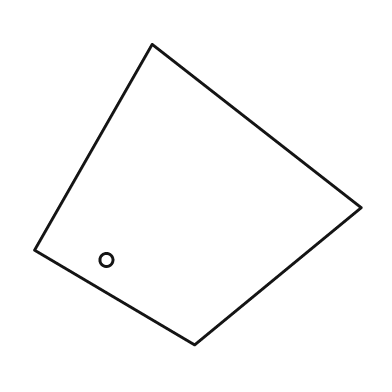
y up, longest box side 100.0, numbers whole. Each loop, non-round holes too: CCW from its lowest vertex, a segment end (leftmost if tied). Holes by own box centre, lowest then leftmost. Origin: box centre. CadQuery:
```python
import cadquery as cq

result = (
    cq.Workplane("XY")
    .moveTo(-1.0, -46.0)
    .lineTo(50.0, -4.0)
    .lineTo(-14.0, 46.0)
    .lineTo(-50.0, -17.0)
    .close()
    .moveTo(-28.0, -20.0)
    .circle(2.0)
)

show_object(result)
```